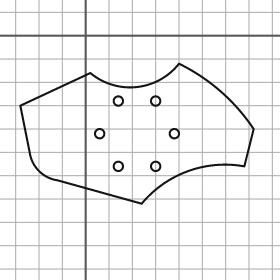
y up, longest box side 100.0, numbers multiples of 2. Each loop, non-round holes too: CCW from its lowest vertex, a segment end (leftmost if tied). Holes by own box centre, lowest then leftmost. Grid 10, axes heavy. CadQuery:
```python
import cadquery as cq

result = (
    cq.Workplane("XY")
    .moveTo(24.0, -72.0)
    .threePointArc((44.0, -58.0), (68.0, -56.0))
    .lineTo(72.0, -40.0)
    .threePointArc((58.0, -24.0), (40.0, -12.0))
    .threePointArc((22.0, -22.0), (2.0, -16.0))
    .lineTo(-28.0, -30.0)
    .lineTo(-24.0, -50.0)
    .threePointArc((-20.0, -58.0), (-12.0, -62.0))
    .close()
    .moveTo(14.0, -56.0)
    .circle(2.0)
    .moveTo(30.0, -56.0)
    .circle(2.0)
    .moveTo(6.0, -42.0)
    .circle(2.0)
    .moveTo(38.0, -42.0)
    .circle(2.0)
    .moveTo(14.0, -28.0)
    .circle(2.0)
    .moveTo(30.0, -28.0)
    .circle(2.0)
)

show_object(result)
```